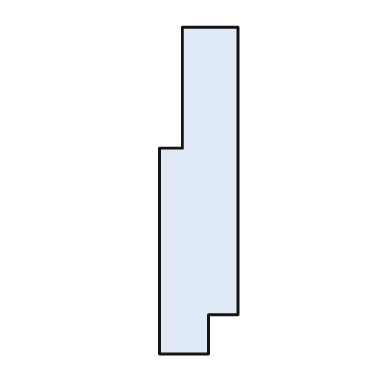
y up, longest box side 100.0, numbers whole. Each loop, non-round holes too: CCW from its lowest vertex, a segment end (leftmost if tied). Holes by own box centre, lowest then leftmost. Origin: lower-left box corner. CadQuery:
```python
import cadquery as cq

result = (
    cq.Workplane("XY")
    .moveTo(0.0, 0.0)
    .lineTo(15.0, 0.0)
    .lineTo(15.0, 12.0)
    .lineTo(24.0, 12.0)
    .lineTo(24.0, 100.0)
    .lineTo(7.0, 100.0)
    .lineTo(7.0, 63.0)
    .lineTo(0.0, 63.0)
    .close()
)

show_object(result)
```